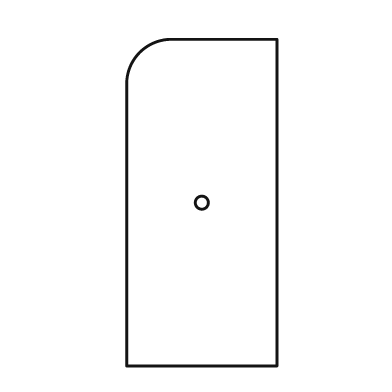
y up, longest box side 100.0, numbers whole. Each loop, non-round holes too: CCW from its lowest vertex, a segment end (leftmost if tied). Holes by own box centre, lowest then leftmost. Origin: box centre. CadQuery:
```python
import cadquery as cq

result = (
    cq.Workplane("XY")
    .moveTo(-23.0, -50.0)
    .lineTo(23.0, -50.0)
    .lineTo(23.0, 50.0)
    .lineTo(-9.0, 50.0)
    .threePointArc((-19.0, 46.0), (-23.0, 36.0))
    .close()
    .moveTo(0.0, 0.0)
    .circle(2.0)
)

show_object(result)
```